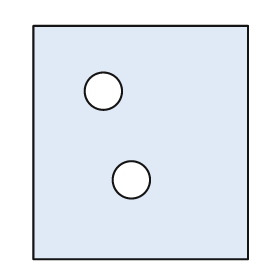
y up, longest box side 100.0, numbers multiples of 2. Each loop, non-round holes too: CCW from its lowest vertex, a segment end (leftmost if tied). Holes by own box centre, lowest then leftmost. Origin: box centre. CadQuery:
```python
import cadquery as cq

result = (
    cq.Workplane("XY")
    .moveTo(-46.0, -50.0)
    .lineTo(46.0, -50.0)
    .lineTo(46.0, 50.0)
    .lineTo(-46.0, 50.0)
    .close()
    .moveTo(-4.0, -16.0)
    .circle(8.0)
    .moveTo(-16.0, 22.0)
    .circle(8.0)
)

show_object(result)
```